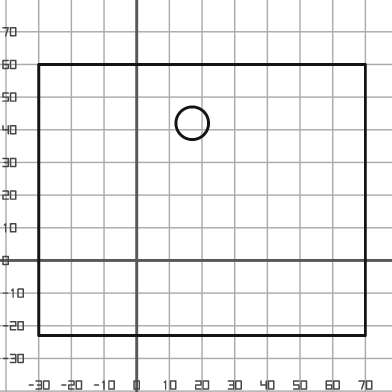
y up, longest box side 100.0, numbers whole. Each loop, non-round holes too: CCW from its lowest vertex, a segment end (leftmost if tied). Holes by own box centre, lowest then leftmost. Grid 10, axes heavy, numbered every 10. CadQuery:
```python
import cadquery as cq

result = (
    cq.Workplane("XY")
    .moveTo(-30.0, -23.0)
    .lineTo(70.0, -23.0)
    .lineTo(70.0, 60.0)
    .lineTo(-30.0, 60.0)
    .close()
    .moveTo(17.0, 42.0)
    .circle(5.0)
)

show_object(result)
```